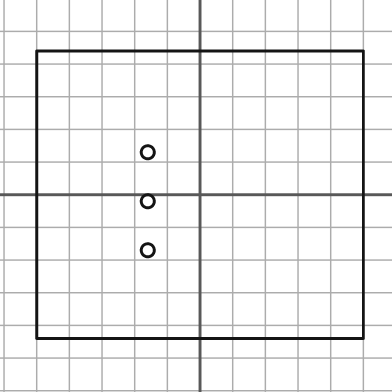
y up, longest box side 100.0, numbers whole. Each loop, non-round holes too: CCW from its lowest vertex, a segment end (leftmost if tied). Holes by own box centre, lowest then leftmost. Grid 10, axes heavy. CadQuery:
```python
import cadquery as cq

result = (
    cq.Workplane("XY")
    .moveTo(-50.0, -44.0)
    .lineTo(50.0, -44.0)
    .lineTo(50.0, 44.0)
    .lineTo(-50.0, 44.0)
    .close()
    .moveTo(-16.0, -17.0)
    .circle(2.0)
    .moveTo(-16.0, -2.0)
    .circle(2.0)
    .moveTo(-16.0, 13.0)
    .circle(2.0)
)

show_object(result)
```